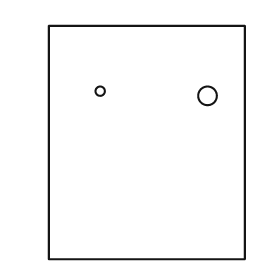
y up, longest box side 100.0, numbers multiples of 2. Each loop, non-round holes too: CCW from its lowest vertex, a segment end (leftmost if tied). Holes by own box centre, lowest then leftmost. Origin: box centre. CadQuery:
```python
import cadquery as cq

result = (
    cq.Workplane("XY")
    .moveTo(-42.0, -50.0)
    .lineTo(42.0, -50.0)
    .lineTo(42.0, 50.0)
    .lineTo(-42.0, 50.0)
    .close()
    .moveTo(26.0, 20.0)
    .circle(4.0)
    .moveTo(-20.0, 22.0)
    .circle(2.0)
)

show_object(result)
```